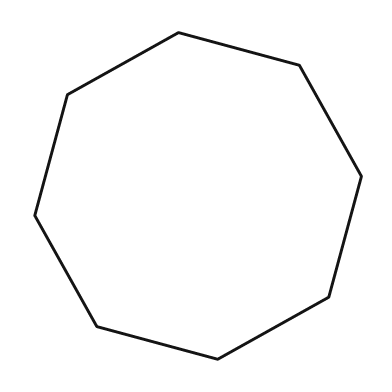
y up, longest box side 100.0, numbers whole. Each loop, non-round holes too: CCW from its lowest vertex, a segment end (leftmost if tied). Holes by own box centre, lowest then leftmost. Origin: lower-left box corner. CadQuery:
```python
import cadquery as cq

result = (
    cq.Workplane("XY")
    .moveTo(56.0, 0.0)
    .lineTo(90.0, 19.0)
    .lineTo(100.0, 56.0)
    .lineTo(81.0, 90.0)
    .lineTo(44.0, 100.0)
    .lineTo(10.0, 81.0)
    .lineTo(0.0, 44.0)
    .lineTo(19.0, 10.0)
    .close()
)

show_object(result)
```